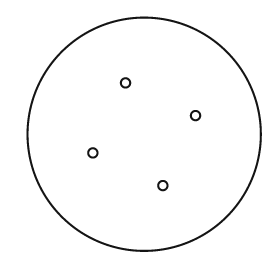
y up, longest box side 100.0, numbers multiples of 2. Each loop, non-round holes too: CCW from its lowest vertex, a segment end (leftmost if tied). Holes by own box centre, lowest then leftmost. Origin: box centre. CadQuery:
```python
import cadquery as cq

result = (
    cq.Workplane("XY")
    .moveTo(0.0, 0.0)
    .circle(50.0)
    .moveTo(8.0, -22.0)
    .circle(2.0)
    .moveTo(-22.0, -8.0)
    .circle(2.0)
    .moveTo(22.0, 8.0)
    .circle(2.0)
    .moveTo(-8.0, 22.0)
    .circle(2.0)
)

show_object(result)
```